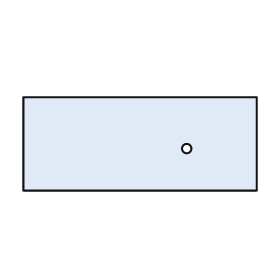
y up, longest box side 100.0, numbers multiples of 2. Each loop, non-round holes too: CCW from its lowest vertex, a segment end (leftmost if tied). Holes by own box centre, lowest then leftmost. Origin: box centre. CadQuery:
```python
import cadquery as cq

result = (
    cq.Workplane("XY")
    .moveTo(-50.0, -20.0)
    .lineTo(50.0, -20.0)
    .lineTo(50.0, 20.0)
    .lineTo(-50.0, 20.0)
    .close()
    .moveTo(20.0, -2.0)
    .circle(2.0)
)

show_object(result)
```